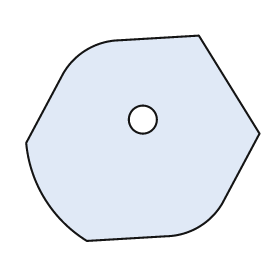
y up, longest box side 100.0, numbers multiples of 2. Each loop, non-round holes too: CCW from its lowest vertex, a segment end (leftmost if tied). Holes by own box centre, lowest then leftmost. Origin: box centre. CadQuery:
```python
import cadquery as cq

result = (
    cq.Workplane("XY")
    .moveTo(-24.0, -44.0)
    .lineTo(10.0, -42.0)
    .threePointArc((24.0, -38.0), (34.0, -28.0))
    .lineTo(50.0, 2.0)
    .lineTo(24.0, 44.0)
    .lineTo(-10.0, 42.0)
    .threePointArc((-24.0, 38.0), (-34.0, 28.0))
    .lineTo(-50.0, -2.0)
    .threePointArc((-42.0, -26.0), (-24.0, -44.0))
    .close()
    .moveTo(0.0, 8.0)
    .circle(6.0)
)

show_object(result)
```